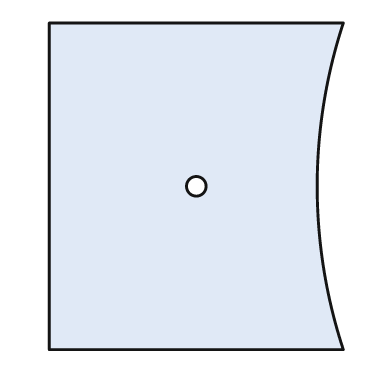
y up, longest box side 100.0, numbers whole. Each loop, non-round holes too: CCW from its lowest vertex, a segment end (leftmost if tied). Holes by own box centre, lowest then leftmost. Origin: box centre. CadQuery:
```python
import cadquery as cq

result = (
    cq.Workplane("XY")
    .moveTo(-45.0, -50.0)
    .lineTo(45.0, -50.0)
    .threePointArc((37.0, 0.0), (45.0, 50.0))
    .lineTo(-45.0, 50.0)
    .close()
    .moveTo(0.0, 0.0)
    .circle(3.0)
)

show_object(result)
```